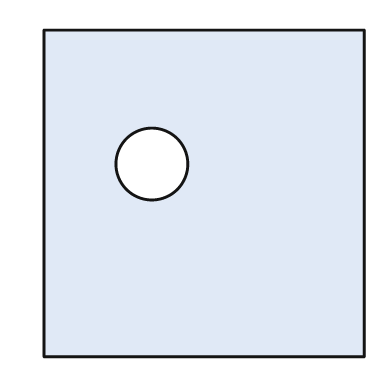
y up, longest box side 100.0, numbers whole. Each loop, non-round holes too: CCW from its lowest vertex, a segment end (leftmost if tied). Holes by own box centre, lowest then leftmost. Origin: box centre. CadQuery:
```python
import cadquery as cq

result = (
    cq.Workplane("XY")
    .moveTo(-49.0, -50.0)
    .lineTo(49.0, -50.0)
    .lineTo(49.0, 50.0)
    .lineTo(-49.0, 50.0)
    .close()
    .moveTo(-16.0, 9.0)
    .circle(11.0)
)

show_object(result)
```